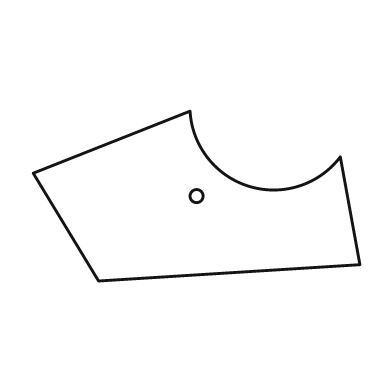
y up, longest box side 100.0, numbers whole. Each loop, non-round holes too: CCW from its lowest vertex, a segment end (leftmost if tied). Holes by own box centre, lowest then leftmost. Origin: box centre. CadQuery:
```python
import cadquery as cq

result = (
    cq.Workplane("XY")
    .moveTo(-30.0, -26.0)
    .lineTo(50.0, -21.0)
    .lineTo(44.0, 12.0)
    .threePointArc((16.0, 3.0), (-2.0, 26.0))
    .lineTo(-50.0, 7.0)
    .close()
    .moveTo(0.0, 0.0)
    .circle(2.0)
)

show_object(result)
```